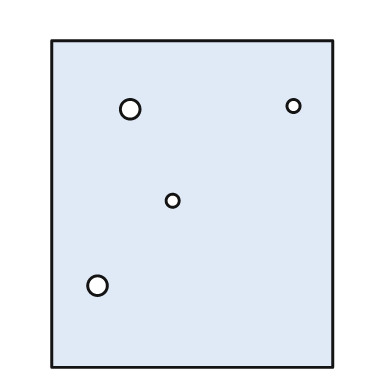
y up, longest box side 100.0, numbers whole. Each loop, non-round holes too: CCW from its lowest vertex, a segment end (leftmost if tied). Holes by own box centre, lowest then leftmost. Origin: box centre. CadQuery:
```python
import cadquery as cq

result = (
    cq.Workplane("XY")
    .moveTo(-43.0, -50.0)
    .lineTo(43.0, -50.0)
    .lineTo(43.0, 50.0)
    .lineTo(-43.0, 50.0)
    .close()
    .moveTo(-29.0, -25.0)
    .circle(3.0)
    .moveTo(-6.0, 1.0)
    .circle(2.0)
    .moveTo(-19.0, 29.0)
    .circle(3.0)
    .moveTo(31.0, 30.0)
    .circle(2.0)
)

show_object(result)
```